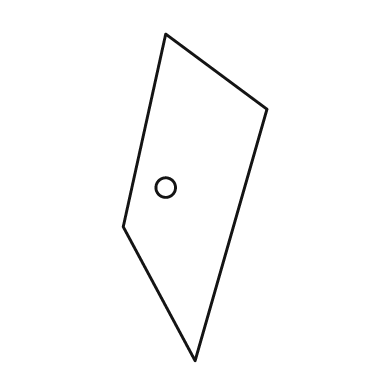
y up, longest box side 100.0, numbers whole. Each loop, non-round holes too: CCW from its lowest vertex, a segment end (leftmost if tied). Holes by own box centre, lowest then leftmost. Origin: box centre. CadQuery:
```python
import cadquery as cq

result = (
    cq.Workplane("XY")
    .moveTo(0.0, -50.0)
    .lineTo(22.0, 27.0)
    .lineTo(-9.0, 50.0)
    .lineTo(-22.0, -9.0)
    .close()
    .moveTo(-9.0, 3.0)
    .circle(3.0)
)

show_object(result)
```